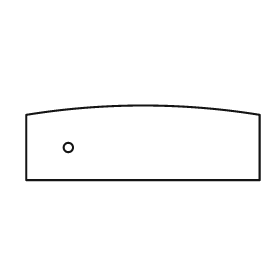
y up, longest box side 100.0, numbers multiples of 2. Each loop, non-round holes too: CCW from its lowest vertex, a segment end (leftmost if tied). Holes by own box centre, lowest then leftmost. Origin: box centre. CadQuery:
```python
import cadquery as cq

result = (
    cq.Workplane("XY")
    .moveTo(-50.0, -16.0)
    .lineTo(50.0, -16.0)
    .lineTo(50.0, 12.0)
    .threePointArc((0.0, 16.0), (-50.0, 12.0))
    .close()
    .moveTo(-32.0, -2.0)
    .circle(2.0)
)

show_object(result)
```